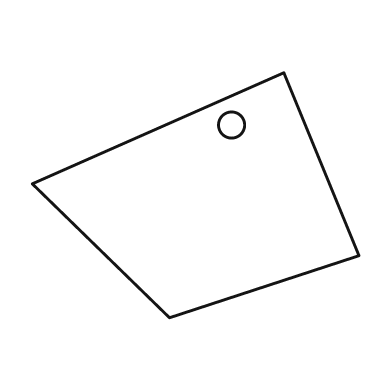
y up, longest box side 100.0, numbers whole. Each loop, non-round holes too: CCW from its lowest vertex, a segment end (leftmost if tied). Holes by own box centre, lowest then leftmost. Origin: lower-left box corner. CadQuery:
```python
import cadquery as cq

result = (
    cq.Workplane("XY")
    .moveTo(42.0, 0.0)
    .lineTo(100.0, 19.0)
    .lineTo(77.0, 75.0)
    .lineTo(0.0, 41.0)
    .close()
    .moveTo(61.0, 59.0)
    .circle(4.0)
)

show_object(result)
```